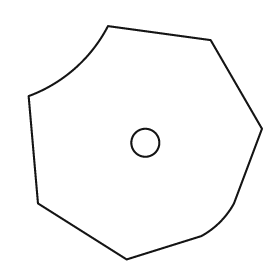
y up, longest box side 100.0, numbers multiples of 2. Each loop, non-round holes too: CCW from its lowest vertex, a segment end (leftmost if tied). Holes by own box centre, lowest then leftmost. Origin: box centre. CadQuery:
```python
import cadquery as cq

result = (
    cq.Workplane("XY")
    .moveTo(-8.0, -50.0)
    .lineTo(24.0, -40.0)
    .threePointArc((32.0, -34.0), (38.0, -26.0))
    .lineTo(50.0, 6.0)
    .lineTo(28.0, 44.0)
    .lineTo(-16.0, 50.0)
    .threePointArc((-30.0, 32.0), (-50.0, 20.0))
    .lineTo(-46.0, -26.0)
    .close()
    .moveTo(0.0, 0.0)
    .circle(6.0)
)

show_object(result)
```